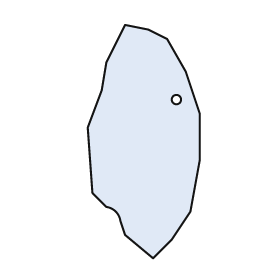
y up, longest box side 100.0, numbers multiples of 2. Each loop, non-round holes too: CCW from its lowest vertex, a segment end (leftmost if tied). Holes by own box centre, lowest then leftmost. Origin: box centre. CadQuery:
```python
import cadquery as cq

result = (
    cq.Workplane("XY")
    .moveTo(4.0, -50.0)
    .lineTo(12.0, -42.0)
    .lineTo(20.0, -30.0)
    .lineTo(24.0, -8.0)
    .lineTo(24.0, 12.0)
    .lineTo(18.0, 30.0)
    .lineTo(10.0, 44.0)
    .lineTo(2.0, 48.0)
    .lineTo(-8.0, 50.0)
    .lineTo(-16.0, 34.0)
    .lineTo(-18.0, 22.0)
    .lineTo(-24.0, 6.0)
    .lineTo(-22.0, -22.0)
    .lineTo(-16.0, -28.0)
    .threePointArc((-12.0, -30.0), (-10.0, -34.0))
    .lineTo(-8.0, -40.0)
    .close()
    .moveTo(14.0, 18.0)
    .circle(2.0)
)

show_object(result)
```